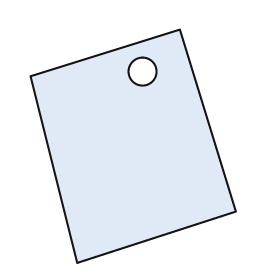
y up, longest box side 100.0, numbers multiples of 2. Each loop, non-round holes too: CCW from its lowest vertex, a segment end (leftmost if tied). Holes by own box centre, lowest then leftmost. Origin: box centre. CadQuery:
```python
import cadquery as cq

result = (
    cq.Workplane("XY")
    .moveTo(-24.0, -50.0)
    .lineTo(44.0, -28.0)
    .lineTo(20.0, 50.0)
    .lineTo(-44.0, 30.0)
    .close()
    .moveTo(4.0, 32.0)
    .circle(6.0)
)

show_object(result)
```